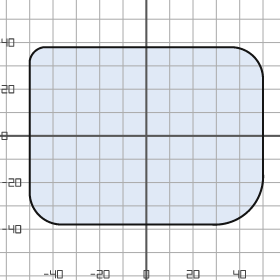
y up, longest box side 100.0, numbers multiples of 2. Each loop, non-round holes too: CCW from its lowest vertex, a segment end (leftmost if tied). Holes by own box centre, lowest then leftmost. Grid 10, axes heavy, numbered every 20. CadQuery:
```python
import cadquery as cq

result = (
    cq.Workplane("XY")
    .moveTo(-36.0, -38.0)
    .lineTo(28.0, -38.0)
    .threePointArc((44.0, -32.0), (50.0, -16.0))
    .lineTo(50.0, 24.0)
    .threePointArc((46.0, 34.0), (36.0, 38.0))
    .lineTo(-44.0, 38.0)
    .threePointArc((-48.0, 36.0), (-50.0, 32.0))
    .lineTo(-50.0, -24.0)
    .threePointArc((-46.0, -34.0), (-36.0, -38.0))
    .close()
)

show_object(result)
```